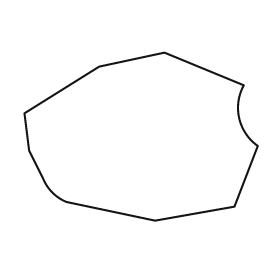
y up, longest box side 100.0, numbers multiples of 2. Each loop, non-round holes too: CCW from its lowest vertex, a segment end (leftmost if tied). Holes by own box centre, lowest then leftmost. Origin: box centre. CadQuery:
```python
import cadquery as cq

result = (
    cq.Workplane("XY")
    .moveTo(6.0, -36.0)
    .lineTo(40.0, -30.0)
    .lineTo(50.0, -4.0)
    .threePointArc((42.0, 8.0), (44.0, 22.0))
    .lineTo(10.0, 36.0)
    .lineTo(-18.0, 30.0)
    .lineTo(-50.0, 10.0)
    .lineTo(-48.0, -6.0)
    .lineTo(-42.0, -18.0)
    .threePointArc((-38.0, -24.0), (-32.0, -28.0))
    .close()
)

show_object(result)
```